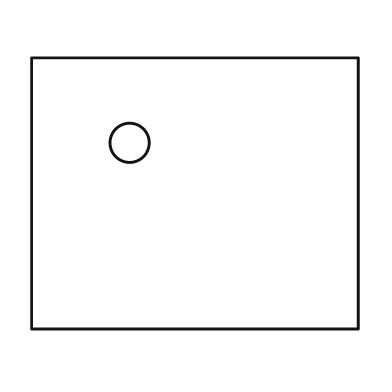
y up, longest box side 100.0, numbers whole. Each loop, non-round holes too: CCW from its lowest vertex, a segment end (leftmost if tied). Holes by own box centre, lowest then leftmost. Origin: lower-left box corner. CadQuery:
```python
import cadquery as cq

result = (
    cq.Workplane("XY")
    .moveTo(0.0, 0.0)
    .lineTo(100.0, 0.0)
    .lineTo(100.0, 83.0)
    .lineTo(0.0, 83.0)
    .close()
    .moveTo(30.0, 57.0)
    .circle(6.0)
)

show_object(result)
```